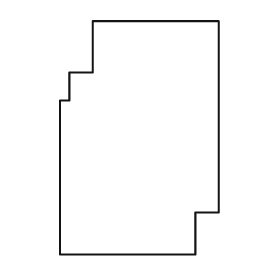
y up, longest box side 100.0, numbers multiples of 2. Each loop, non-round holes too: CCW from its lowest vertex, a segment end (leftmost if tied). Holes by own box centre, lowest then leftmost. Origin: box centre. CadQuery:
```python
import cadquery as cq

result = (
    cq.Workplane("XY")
    .moveTo(-34.0, -50.0)
    .lineTo(24.0, -50.0)
    .lineTo(24.0, -32.0)
    .lineTo(34.0, -32.0)
    .lineTo(34.0, 50.0)
    .lineTo(-20.0, 50.0)
    .lineTo(-20.0, 28.0)
    .lineTo(-30.0, 28.0)
    .lineTo(-30.0, 16.0)
    .lineTo(-34.0, 16.0)
    .close()
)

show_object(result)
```